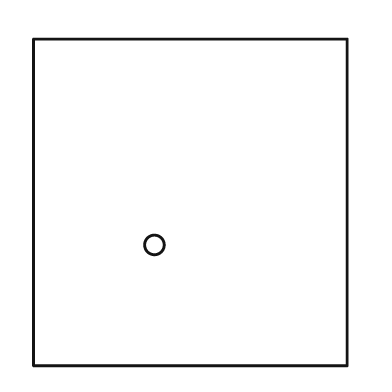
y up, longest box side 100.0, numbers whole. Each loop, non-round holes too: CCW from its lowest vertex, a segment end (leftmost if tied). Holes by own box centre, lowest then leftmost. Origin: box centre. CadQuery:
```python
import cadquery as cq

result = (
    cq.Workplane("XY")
    .moveTo(-48.0, -50.0)
    .lineTo(48.0, -50.0)
    .lineTo(48.0, 50.0)
    .lineTo(-48.0, 50.0)
    .close()
    .moveTo(-11.0, -13.0)
    .circle(3.0)
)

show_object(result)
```